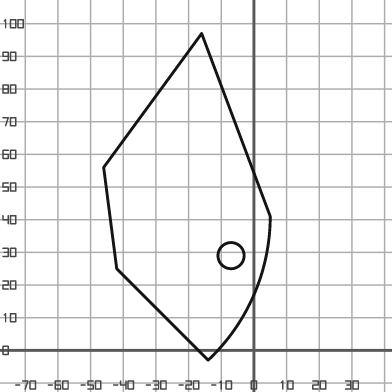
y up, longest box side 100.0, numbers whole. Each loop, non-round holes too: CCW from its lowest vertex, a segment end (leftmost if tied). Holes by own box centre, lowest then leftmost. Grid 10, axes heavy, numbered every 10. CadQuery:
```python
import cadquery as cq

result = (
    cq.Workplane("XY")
    .moveTo(-14.0, -3.0)
    .threePointArc((0.0, 17.0), (5.0, 41.0))
    .lineTo(-16.0, 97.0)
    .lineTo(-46.0, 56.0)
    .lineTo(-42.0, 25.0)
    .close()
    .moveTo(-7.0, 29.0)
    .circle(4.0)
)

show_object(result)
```